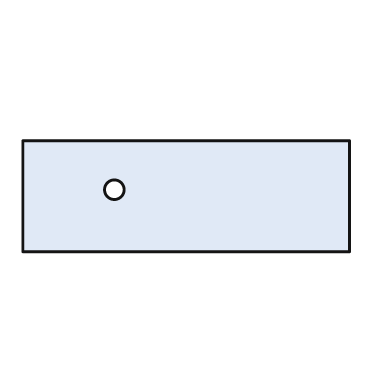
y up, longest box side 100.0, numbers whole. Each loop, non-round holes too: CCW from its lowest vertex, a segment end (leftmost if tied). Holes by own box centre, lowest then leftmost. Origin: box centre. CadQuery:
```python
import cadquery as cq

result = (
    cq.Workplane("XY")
    .moveTo(-50.0, -17.0)
    .lineTo(50.0, -17.0)
    .lineTo(50.0, 17.0)
    .lineTo(-50.0, 17.0)
    .close()
    .moveTo(-22.0, 2.0)
    .circle(3.0)
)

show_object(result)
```